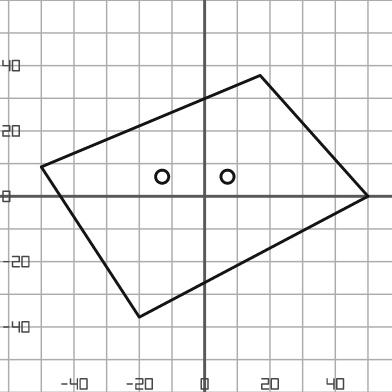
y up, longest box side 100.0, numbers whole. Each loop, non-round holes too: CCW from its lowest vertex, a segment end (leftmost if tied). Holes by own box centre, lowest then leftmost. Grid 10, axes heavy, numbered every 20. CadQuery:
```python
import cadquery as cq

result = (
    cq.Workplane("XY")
    .moveTo(-20.0, -37.0)
    .lineTo(50.0, 0.0)
    .lineTo(17.0, 37.0)
    .lineTo(-50.0, 9.0)
    .close()
    .moveTo(-13.0, 6.0)
    .circle(2.0)
    .moveTo(7.0, 6.0)
    .circle(2.0)
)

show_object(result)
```